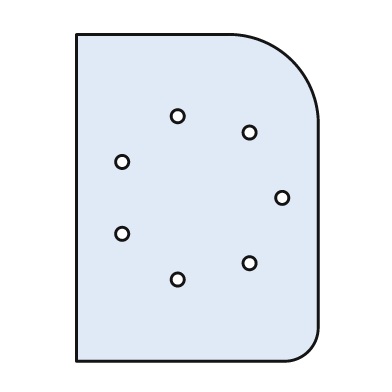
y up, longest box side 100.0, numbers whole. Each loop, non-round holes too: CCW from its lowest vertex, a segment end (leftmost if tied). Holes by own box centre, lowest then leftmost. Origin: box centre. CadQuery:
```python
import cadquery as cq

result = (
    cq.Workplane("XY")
    .moveTo(-37.0, -50.0)
    .lineTo(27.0, -50.0)
    .threePointArc((34.0, -47.0), (37.0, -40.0))
    .lineTo(37.0, 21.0)
    .threePointArc((29.0, 42.0), (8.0, 50.0))
    .lineTo(-37.0, 50.0)
    .close()
    .moveTo(-6.0, -25.0)
    .circle(2.0)
    .moveTo(16.0, -20.0)
    .circle(2.0)
    .moveTo(-23.0, -11.0)
    .circle(2.0)
    .moveTo(26.0, 0.0)
    .circle(2.0)
    .moveTo(-23.0, 11.0)
    .circle(2.0)
    .moveTo(16.0, 20.0)
    .circle(2.0)
    .moveTo(-6.0, 25.0)
    .circle(2.0)
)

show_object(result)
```